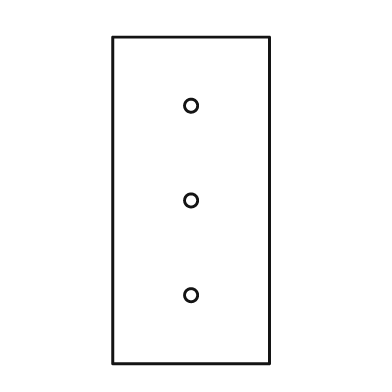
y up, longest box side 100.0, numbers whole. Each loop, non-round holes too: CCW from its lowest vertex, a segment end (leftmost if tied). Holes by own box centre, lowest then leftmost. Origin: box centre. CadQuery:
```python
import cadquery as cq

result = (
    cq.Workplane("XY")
    .moveTo(-24.0, -50.0)
    .lineTo(24.0, -50.0)
    .lineTo(24.0, 50.0)
    .lineTo(-24.0, 50.0)
    .close()
    .moveTo(0.0, -29.0)
    .circle(2.0)
    .moveTo(0.0, 0.0)
    .circle(2.0)
    .moveTo(0.0, 29.0)
    .circle(2.0)
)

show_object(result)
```